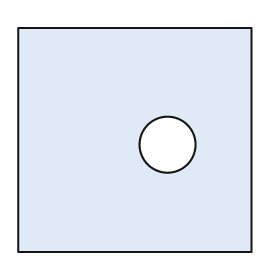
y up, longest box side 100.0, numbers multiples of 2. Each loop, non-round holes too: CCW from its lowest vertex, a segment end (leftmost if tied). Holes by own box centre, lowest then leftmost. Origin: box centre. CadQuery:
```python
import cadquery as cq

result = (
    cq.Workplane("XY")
    .moveTo(-50.0, -48.0)
    .lineTo(50.0, -48.0)
    .lineTo(50.0, 48.0)
    .lineTo(-50.0, 48.0)
    .close()
    .moveTo(14.0, -2.0)
    .circle(12.0)
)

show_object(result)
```